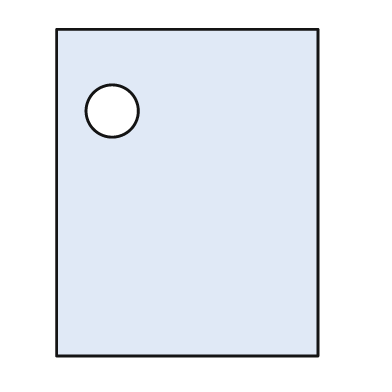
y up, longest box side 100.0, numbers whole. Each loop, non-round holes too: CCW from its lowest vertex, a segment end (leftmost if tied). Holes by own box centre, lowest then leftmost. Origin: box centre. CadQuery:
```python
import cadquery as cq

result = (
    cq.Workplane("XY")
    .moveTo(-40.0, -50.0)
    .lineTo(40.0, -50.0)
    .lineTo(40.0, 50.0)
    .lineTo(-40.0, 50.0)
    .close()
    .moveTo(-23.0, 25.0)
    .circle(8.0)
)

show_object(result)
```